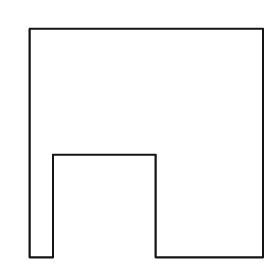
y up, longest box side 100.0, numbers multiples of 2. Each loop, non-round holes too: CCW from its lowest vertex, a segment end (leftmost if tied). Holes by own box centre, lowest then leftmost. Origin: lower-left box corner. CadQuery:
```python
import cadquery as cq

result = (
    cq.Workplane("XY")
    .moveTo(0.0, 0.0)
    .lineTo(10.0, 0.0)
    .lineTo(10.0, 44.0)
    .lineTo(54.0, 44.0)
    .lineTo(54.0, 0.0)
    .lineTo(100.0, 0.0)
    .lineTo(100.0, 98.0)
    .lineTo(0.0, 98.0)
    .close()
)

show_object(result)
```